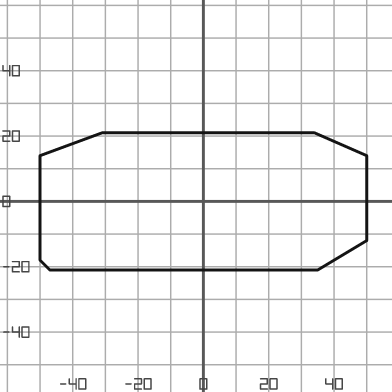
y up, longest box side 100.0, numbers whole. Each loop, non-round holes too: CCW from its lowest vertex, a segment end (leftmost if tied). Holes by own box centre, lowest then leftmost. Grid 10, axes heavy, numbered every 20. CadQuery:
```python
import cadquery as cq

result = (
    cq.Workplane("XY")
    .moveTo(-47.0, -21.0)
    .lineTo(35.0, -21.0)
    .lineTo(50.0, -12.0)
    .lineTo(50.0, 14.0)
    .lineTo(34.0, 21.0)
    .lineTo(-31.0, 21.0)
    .lineTo(-50.0, 14.0)
    .lineTo(-50.0, -18.0)
    .close()
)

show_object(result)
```